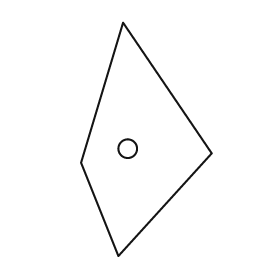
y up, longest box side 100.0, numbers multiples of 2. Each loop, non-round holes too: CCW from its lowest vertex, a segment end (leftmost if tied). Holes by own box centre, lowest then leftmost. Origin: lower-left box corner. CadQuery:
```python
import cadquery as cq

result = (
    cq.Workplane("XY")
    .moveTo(16.0, 0.0)
    .lineTo(56.0, 44.0)
    .lineTo(18.0, 100.0)
    .lineTo(0.0, 40.0)
    .close()
    .moveTo(20.0, 46.0)
    .circle(4.0)
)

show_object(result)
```